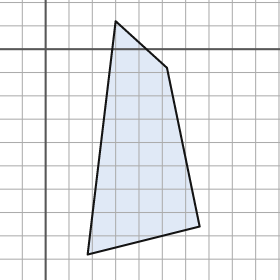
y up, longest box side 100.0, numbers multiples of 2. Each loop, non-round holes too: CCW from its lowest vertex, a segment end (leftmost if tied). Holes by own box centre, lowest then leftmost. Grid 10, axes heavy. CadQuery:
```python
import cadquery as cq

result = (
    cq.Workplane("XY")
    .moveTo(18.0, -88.0)
    .lineTo(66.0, -76.0)
    .lineTo(52.0, -8.0)
    .lineTo(30.0, 12.0)
    .close()
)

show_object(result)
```